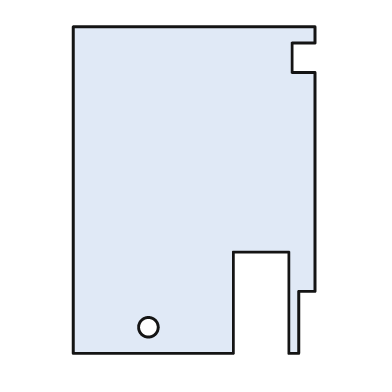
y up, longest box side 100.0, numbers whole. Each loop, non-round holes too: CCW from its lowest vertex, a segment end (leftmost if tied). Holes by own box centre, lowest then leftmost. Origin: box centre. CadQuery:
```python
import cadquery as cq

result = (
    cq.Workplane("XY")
    .moveTo(-37.0, -50.0)
    .lineTo(12.0, -50.0)
    .lineTo(12.0, -19.0)
    .lineTo(29.0, -19.0)
    .lineTo(29.0, -50.0)
    .lineTo(32.0, -50.0)
    .lineTo(32.0, -31.0)
    .lineTo(37.0, -31.0)
    .lineTo(37.0, 36.0)
    .lineTo(30.0, 36.0)
    .lineTo(30.0, 45.0)
    .lineTo(37.0, 45.0)
    .lineTo(37.0, 50.0)
    .lineTo(-37.0, 50.0)
    .close()
    .moveTo(-14.0, -42.0)
    .circle(3.0)
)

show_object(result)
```